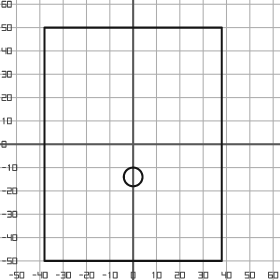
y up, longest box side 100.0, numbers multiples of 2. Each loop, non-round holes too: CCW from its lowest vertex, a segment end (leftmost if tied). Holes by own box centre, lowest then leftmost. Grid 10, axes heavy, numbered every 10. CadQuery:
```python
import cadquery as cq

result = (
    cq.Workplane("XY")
    .moveTo(-38.0, -50.0)
    .lineTo(38.0, -50.0)
    .lineTo(38.0, 50.0)
    .lineTo(-38.0, 50.0)
    .close()
    .moveTo(0.0, -14.0)
    .circle(4.0)
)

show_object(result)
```